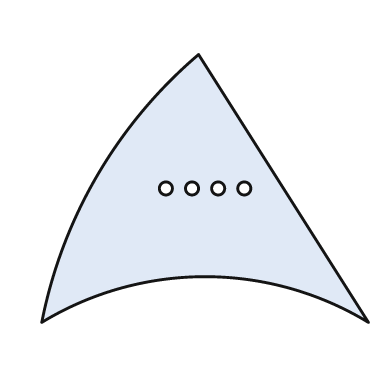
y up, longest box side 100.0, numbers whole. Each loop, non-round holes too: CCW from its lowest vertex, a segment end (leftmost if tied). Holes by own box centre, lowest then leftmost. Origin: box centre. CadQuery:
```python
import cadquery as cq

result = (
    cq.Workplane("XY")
    .moveTo(-50.0, -41.0)
    .threePointArc((0.0, -27.0), (50.0, -41.0))
    .lineTo(-2.0, 41.0)
    .threePointArc((-33.0, 4.0), (-50.0, -41.0))
    .close()
    .moveTo(-12.0, 0.0)
    .circle(2.0)
    .moveTo(-4.0, 0.0)
    .circle(2.0)
    .moveTo(4.0, 0.0)
    .circle(2.0)
    .moveTo(12.0, 0.0)
    .circle(2.0)
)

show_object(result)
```